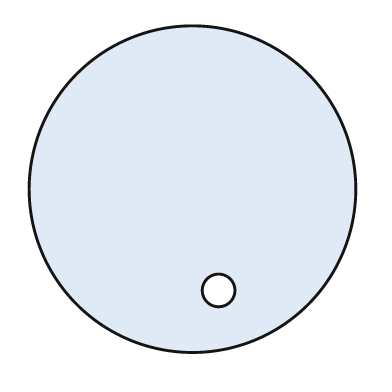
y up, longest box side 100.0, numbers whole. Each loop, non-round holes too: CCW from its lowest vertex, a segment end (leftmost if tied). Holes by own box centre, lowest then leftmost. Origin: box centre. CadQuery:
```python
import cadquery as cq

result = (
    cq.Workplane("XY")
    .moveTo(0.0, 0.0)
    .circle(50.0)
    .moveTo(8.0, -31.0)
    .circle(5.0)
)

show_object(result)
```